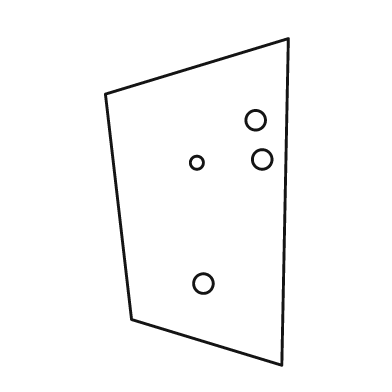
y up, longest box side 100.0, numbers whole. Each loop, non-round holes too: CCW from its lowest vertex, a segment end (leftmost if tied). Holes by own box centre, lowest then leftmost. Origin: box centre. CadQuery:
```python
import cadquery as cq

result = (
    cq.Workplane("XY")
    .moveTo(26.0, -50.0)
    .lineTo(28.0, 50.0)
    .lineTo(-28.0, 33.0)
    .lineTo(-20.0, -36.0)
    .close()
    .moveTo(2.0, -25.0)
    .circle(3.0)
    .moveTo(0.0, 12.0)
    .circle(2.0)
    .moveTo(20.0, 13.0)
    .circle(3.0)
    .moveTo(18.0, 25.0)
    .circle(3.0)
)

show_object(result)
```